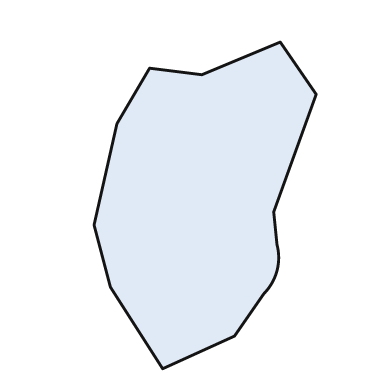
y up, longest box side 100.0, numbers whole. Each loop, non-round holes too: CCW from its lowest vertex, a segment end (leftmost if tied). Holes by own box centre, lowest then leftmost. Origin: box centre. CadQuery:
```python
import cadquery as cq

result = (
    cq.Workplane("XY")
    .moveTo(-13.0, -50.0)
    .lineTo(9.0, -40.0)
    .lineTo(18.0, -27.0)
    .threePointArc((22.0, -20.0), (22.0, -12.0))
    .lineTo(21.0, -2.0)
    .lineTo(34.0, 34.0)
    .lineTo(23.0, 50.0)
    .lineTo(-1.0, 40.0)
    .lineTo(-17.0, 42.0)
    .lineTo(-27.0, 25.0)
    .lineTo(-34.0, -6.0)
    .lineTo(-29.0, -25.0)
    .close()
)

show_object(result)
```